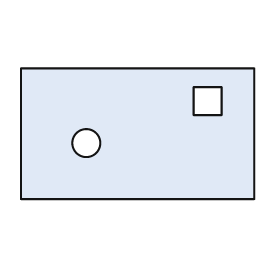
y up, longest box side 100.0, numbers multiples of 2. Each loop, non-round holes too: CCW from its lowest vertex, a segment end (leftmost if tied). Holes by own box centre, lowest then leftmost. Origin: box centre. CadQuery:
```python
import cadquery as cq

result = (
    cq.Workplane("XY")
    .moveTo(-50.0, -28.0)
    .lineTo(50.0, -28.0)
    .lineTo(50.0, 28.0)
    .lineTo(-50.0, 28.0)
    .close()
    .moveTo(-22.0, -4.0)
    .circle(6.0)
    .moveTo(24.0, 8.0)
    .lineTo(36.0, 8.0)
    .lineTo(36.0, 20.0)
    .lineTo(24.0, 20.0)
    .close()
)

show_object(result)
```